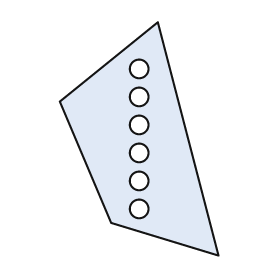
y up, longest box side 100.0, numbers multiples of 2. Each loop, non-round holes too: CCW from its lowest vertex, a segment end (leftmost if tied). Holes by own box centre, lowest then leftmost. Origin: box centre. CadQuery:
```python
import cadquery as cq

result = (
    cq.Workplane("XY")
    .moveTo(34.0, -50.0)
    .lineTo(8.0, 50.0)
    .lineTo(-34.0, 16.0)
    .lineTo(-12.0, -36.0)
    .close()
    .moveTo(0.0, -30.0)
    .circle(4.0)
    .moveTo(0.0, -18.0)
    .circle(4.0)
    .moveTo(0.0, -6.0)
    .circle(4.0)
    .moveTo(0.0, 6.0)
    .circle(4.0)
    .moveTo(0.0, 18.0)
    .circle(4.0)
    .moveTo(0.0, 30.0)
    .circle(4.0)
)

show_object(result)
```